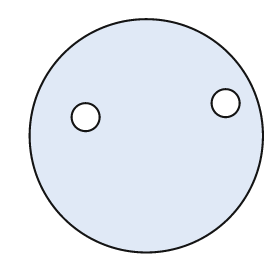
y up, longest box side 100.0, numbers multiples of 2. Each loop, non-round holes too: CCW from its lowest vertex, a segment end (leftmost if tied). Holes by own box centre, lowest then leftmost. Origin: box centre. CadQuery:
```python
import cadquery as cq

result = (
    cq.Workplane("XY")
    .moveTo(0.0, 0.0)
    .circle(50.0)
    .moveTo(-26.0, 8.0)
    .circle(6.0)
    .moveTo(34.0, 14.0)
    .circle(6.0)
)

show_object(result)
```